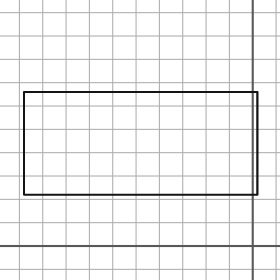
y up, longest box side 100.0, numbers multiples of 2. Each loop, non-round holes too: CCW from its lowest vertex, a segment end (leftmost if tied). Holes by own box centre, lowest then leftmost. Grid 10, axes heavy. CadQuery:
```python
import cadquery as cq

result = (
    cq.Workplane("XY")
    .moveTo(-98.0, 22.0)
    .lineTo(2.0, 22.0)
    .lineTo(2.0, 66.0)
    .lineTo(-98.0, 66.0)
    .close()
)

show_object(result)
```